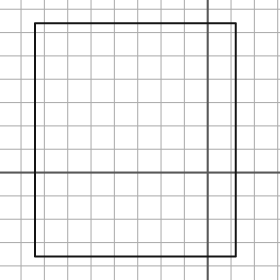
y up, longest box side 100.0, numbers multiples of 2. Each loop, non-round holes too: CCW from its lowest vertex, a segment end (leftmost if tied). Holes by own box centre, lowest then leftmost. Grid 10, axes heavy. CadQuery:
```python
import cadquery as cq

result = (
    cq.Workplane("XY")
    .moveTo(-74.0, -36.0)
    .lineTo(12.0, -36.0)
    .lineTo(12.0, 64.0)
    .lineTo(-74.0, 64.0)
    .close()
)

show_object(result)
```